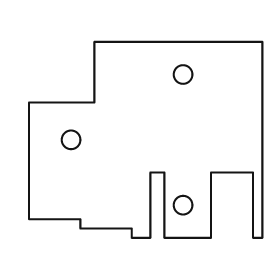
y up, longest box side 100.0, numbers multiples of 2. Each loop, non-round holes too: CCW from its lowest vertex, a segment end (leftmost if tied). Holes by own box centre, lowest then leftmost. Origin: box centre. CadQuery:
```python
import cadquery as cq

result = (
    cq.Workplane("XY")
    .moveTo(-6.0, -42.0)
    .lineTo(2.0, -42.0)
    .lineTo(2.0, -14.0)
    .lineTo(8.0, -14.0)
    .lineTo(8.0, -42.0)
    .lineTo(28.0, -42.0)
    .lineTo(28.0, -14.0)
    .lineTo(46.0, -14.0)
    .lineTo(46.0, -42.0)
    .lineTo(50.0, -42.0)
    .lineTo(50.0, 42.0)
    .lineTo(-22.0, 42.0)
    .lineTo(-22.0, 16.0)
    .lineTo(-50.0, 16.0)
    .lineTo(-50.0, -34.0)
    .lineTo(-28.0, -34.0)
    .lineTo(-28.0, -38.0)
    .lineTo(-6.0, -38.0)
    .close()
    .moveTo(16.0, -28.0)
    .circle(4.0)
    .moveTo(-32.0, 0.0)
    .circle(4.0)
    .moveTo(16.0, 28.0)
    .circle(4.0)
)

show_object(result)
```